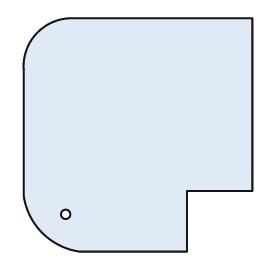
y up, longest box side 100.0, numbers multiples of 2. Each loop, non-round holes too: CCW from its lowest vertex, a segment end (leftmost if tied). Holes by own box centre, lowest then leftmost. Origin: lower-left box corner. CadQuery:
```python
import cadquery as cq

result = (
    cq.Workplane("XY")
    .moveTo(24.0, 0.0)
    .lineTo(70.0, 0.0)
    .lineTo(70.0, 26.0)
    .lineTo(98.0, 26.0)
    .lineTo(98.0, 100.0)
    .lineTo(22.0, 100.0)
    .threePointArc((6.0, 94.0), (0.0, 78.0))
    .lineTo(0.0, 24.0)
    .threePointArc((8.0, 8.0), (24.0, 0.0))
    .close()
    .moveTo(18.0, 16.0)
    .circle(2.0)
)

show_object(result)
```